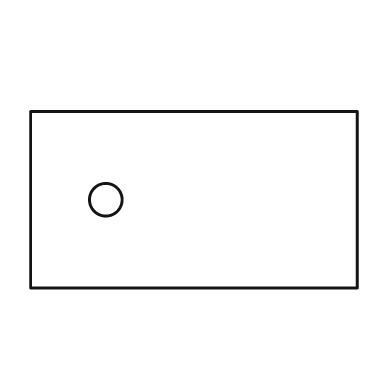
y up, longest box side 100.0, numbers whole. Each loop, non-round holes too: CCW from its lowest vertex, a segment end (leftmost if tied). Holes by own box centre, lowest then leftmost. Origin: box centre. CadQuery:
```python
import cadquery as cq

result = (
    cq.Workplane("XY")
    .moveTo(-50.0, -27.0)
    .lineTo(50.0, -27.0)
    .lineTo(50.0, 27.0)
    .lineTo(-50.0, 27.0)
    .close()
    .moveTo(-27.0, 0.0)
    .circle(5.0)
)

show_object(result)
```